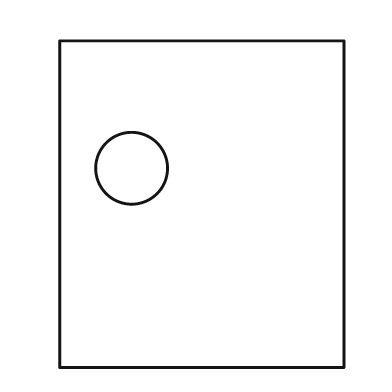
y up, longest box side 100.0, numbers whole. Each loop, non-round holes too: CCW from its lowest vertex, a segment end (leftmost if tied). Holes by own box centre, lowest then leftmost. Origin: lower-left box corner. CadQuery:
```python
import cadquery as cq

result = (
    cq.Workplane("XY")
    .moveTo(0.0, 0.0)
    .lineTo(87.0, 0.0)
    .lineTo(87.0, 100.0)
    .lineTo(0.0, 100.0)
    .close()
    .moveTo(22.0, 61.0)
    .circle(11.0)
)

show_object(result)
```